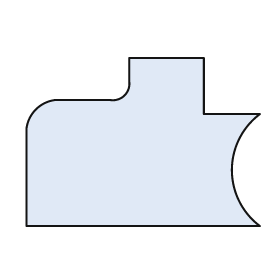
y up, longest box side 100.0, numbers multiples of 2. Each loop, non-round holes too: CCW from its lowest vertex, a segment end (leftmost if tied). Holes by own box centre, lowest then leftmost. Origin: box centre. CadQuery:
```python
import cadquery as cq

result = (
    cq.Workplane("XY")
    .moveTo(-50.0, -36.0)
    .lineTo(50.0, -36.0)
    .threePointArc((38.0, -12.0), (50.0, 12.0))
    .lineTo(26.0, 12.0)
    .lineTo(26.0, 36.0)
    .lineTo(-6.0, 36.0)
    .lineTo(-6.0, 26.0)
    .threePointArc((-8.0, 20.0), (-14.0, 18.0))
    .lineTo(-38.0, 18.0)
    .threePointArc((-46.0, 14.0), (-50.0, 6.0))
    .close()
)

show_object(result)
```